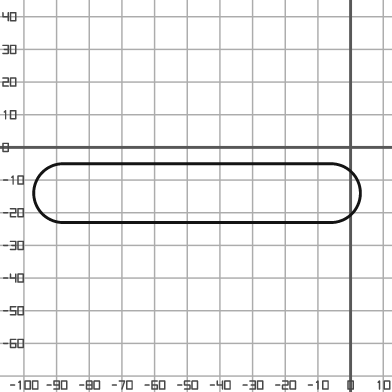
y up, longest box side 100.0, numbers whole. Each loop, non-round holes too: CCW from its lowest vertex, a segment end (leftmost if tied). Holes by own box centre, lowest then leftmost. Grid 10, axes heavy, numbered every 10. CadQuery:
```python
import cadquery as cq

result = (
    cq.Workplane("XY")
    .moveTo(-88.0, -23.0)
    .lineTo(-6.0, -23.0)
    .threePointArc((3.0, -14.0), (-6.0, -5.0))
    .lineTo(-88.0, -5.0)
    .threePointArc((-97.0, -14.0), (-88.0, -23.0))
    .close()
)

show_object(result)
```